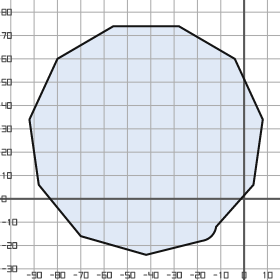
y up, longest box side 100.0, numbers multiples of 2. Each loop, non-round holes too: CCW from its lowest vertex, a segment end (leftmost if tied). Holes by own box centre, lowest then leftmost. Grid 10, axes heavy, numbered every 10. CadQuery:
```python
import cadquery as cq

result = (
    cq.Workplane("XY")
    .moveTo(-42.0, -24.0)
    .lineTo(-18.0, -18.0)
    .threePointArc((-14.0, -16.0), (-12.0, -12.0))
    .lineTo(4.0, 6.0)
    .lineTo(8.0, 34.0)
    .lineTo(-4.0, 60.0)
    .lineTo(-28.0, 74.0)
    .lineTo(-56.0, 74.0)
    .lineTo(-80.0, 60.0)
    .lineTo(-92.0, 34.0)
    .lineTo(-88.0, 6.0)
    .lineTo(-70.0, -16.0)
    .close()
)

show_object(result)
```